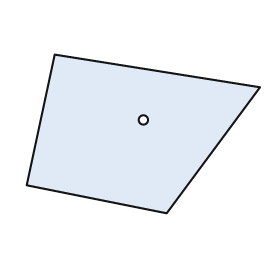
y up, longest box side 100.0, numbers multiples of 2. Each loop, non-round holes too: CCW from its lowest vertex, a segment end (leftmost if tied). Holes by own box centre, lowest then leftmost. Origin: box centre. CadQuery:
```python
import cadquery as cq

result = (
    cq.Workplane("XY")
    .moveTo(10.0, -34.0)
    .lineTo(50.0, 20.0)
    .lineTo(-38.0, 34.0)
    .lineTo(-50.0, -22.0)
    .close()
    .moveTo(0.0, 6.0)
    .circle(2.0)
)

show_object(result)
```